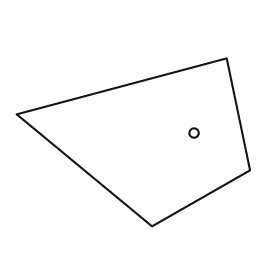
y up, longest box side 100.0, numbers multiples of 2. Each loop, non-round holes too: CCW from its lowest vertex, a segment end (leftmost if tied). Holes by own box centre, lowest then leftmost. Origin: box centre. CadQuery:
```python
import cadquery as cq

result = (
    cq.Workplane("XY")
    .moveTo(8.0, -36.0)
    .lineTo(50.0, -12.0)
    .lineTo(40.0, 36.0)
    .lineTo(-50.0, 12.0)
    .close()
    .moveTo(26.0, 4.0)
    .circle(2.0)
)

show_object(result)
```